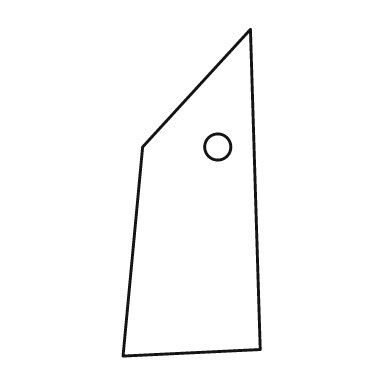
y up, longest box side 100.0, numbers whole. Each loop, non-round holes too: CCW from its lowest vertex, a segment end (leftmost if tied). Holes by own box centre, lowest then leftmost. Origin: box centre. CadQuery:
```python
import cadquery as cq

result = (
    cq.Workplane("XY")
    .moveTo(-21.0, -50.0)
    .lineTo(21.0, -48.0)
    .lineTo(18.0, 50.0)
    .lineTo(-15.0, 14.0)
    .close()
    .moveTo(8.0, 14.0)
    .circle(4.0)
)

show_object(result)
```